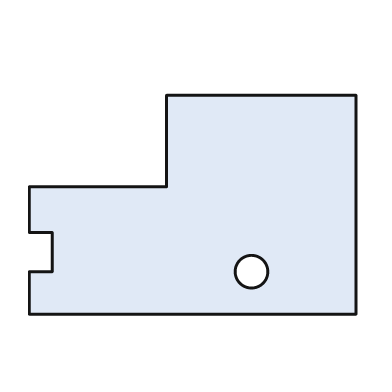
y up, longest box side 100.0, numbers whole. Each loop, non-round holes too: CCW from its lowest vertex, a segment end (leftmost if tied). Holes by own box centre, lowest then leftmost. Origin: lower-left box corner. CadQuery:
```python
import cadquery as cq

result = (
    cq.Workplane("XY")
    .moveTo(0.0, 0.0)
    .lineTo(100.0, 0.0)
    .lineTo(100.0, 67.0)
    .lineTo(42.0, 67.0)
    .lineTo(42.0, 39.0)
    .lineTo(0.0, 39.0)
    .lineTo(0.0, 25.0)
    .lineTo(7.0, 25.0)
    .lineTo(7.0, 13.0)
    .lineTo(0.0, 13.0)
    .close()
    .moveTo(68.0, 13.0)
    .circle(5.0)
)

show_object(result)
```